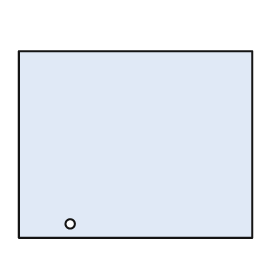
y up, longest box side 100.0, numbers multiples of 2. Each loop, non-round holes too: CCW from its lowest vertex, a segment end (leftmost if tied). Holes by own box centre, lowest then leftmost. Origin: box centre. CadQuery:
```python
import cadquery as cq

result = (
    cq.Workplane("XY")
    .moveTo(-50.0, -40.0)
    .lineTo(50.0, -40.0)
    .lineTo(50.0, 40.0)
    .lineTo(-50.0, 40.0)
    .close()
    .moveTo(-28.0, -34.0)
    .circle(2.0)
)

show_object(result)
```